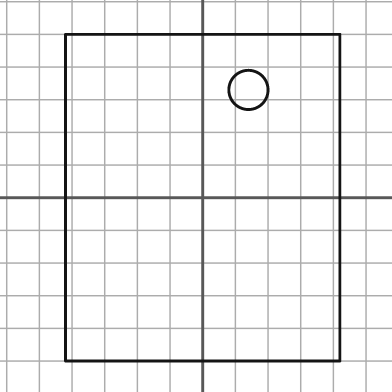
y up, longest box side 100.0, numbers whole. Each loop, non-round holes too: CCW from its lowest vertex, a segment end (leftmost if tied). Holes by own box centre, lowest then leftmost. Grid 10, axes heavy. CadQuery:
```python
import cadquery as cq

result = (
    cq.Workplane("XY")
    .moveTo(-42.0, -50.0)
    .lineTo(42.0, -50.0)
    .lineTo(42.0, 50.0)
    .lineTo(-42.0, 50.0)
    .close()
    .moveTo(14.0, 33.0)
    .circle(6.0)
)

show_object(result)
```